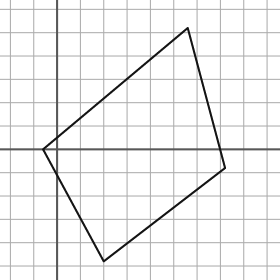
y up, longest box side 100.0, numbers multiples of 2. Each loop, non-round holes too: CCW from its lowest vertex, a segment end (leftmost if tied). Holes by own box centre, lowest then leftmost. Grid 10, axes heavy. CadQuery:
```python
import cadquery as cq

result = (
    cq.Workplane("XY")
    .moveTo(20.0, -48.0)
    .lineTo(72.0, -8.0)
    .lineTo(56.0, 52.0)
    .lineTo(-6.0, 0.0)
    .close()
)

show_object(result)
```